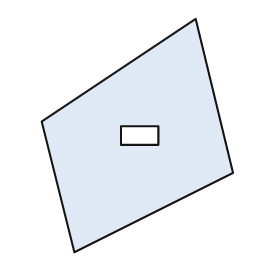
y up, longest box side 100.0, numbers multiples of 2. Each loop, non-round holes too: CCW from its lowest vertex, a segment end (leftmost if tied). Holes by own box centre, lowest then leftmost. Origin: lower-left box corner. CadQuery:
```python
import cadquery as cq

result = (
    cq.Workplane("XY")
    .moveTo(14.0, 0.0)
    .lineTo(82.0, 34.0)
    .lineTo(66.0, 100.0)
    .lineTo(0.0, 56.0)
    .close()
    .moveTo(34.0, 46.0)
    .lineTo(50.0, 46.0)
    .lineTo(50.0, 54.0)
    .lineTo(34.0, 54.0)
    .close()
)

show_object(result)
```